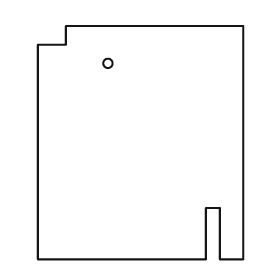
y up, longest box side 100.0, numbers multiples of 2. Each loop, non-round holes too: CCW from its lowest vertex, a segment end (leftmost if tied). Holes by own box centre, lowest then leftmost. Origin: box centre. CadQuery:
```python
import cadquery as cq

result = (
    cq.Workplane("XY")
    .moveTo(-44.0, -50.0)
    .lineTo(28.0, -50.0)
    .lineTo(28.0, -28.0)
    .lineTo(34.0, -28.0)
    .lineTo(34.0, -50.0)
    .lineTo(44.0, -50.0)
    .lineTo(44.0, 50.0)
    .lineTo(-32.0, 50.0)
    .lineTo(-32.0, 42.0)
    .lineTo(-44.0, 42.0)
    .close()
    .moveTo(-14.0, 34.0)
    .circle(2.0)
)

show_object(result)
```